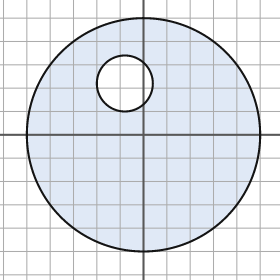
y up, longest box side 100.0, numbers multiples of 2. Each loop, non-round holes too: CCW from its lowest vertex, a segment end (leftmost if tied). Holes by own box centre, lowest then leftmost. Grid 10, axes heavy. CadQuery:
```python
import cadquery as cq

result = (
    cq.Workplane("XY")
    .moveTo(0.0, 0.0)
    .circle(50.0)
    .moveTo(-8.0, 22.0)
    .circle(12.0)
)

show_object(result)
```